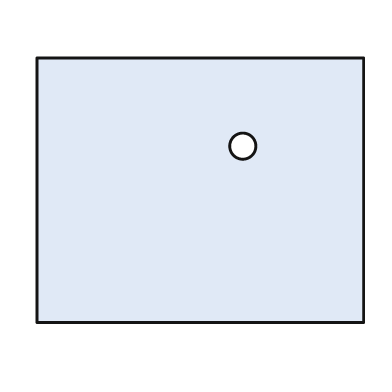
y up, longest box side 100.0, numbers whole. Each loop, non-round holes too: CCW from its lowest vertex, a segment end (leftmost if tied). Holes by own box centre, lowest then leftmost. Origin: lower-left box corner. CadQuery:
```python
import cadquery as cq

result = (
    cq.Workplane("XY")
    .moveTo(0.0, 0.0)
    .lineTo(100.0, 0.0)
    .lineTo(100.0, 81.0)
    .lineTo(0.0, 81.0)
    .close()
    .moveTo(63.0, 54.0)
    .circle(4.0)
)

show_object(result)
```